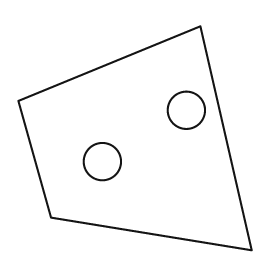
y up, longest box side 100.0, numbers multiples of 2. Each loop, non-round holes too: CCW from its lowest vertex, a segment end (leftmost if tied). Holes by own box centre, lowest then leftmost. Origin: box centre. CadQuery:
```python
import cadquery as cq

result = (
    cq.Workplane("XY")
    .moveTo(50.0, -48.0)
    .lineTo(28.0, 48.0)
    .lineTo(-50.0, 16.0)
    .lineTo(-36.0, -34.0)
    .close()
    .moveTo(-14.0, -10.0)
    .circle(8.0)
    .moveTo(22.0, 12.0)
    .circle(8.0)
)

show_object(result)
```